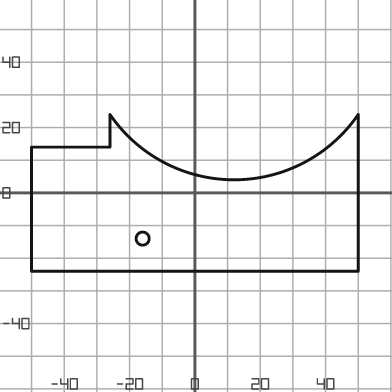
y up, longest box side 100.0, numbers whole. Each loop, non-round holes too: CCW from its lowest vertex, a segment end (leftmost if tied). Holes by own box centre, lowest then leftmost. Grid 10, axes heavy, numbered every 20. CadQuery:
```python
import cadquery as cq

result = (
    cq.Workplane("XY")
    .moveTo(-50.0, -24.0)
    .lineTo(50.0, -24.0)
    .lineTo(50.0, 24.0)
    .threePointArc((12.0, 4.0), (-26.0, 24.0))
    .lineTo(-26.0, 14.0)
    .lineTo(-50.0, 14.0)
    .close()
    .moveTo(-16.0, -14.0)
    .circle(2.0)
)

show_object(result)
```